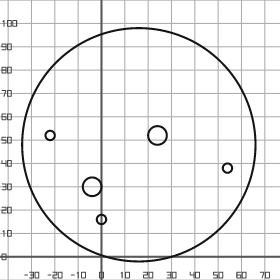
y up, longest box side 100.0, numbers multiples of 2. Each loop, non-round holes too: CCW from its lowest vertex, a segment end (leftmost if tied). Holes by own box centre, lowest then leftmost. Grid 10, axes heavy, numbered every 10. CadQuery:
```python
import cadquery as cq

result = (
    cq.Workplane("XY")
    .moveTo(16.0, 48.0)
    .circle(50.0)
    .moveTo(0.0, 16.0)
    .circle(2.0)
    .moveTo(-4.0, 30.0)
    .circle(4.0)
    .moveTo(54.0, 38.0)
    .circle(2.0)
    .moveTo(-22.0, 52.0)
    .circle(2.0)
    .moveTo(24.0, 52.0)
    .circle(4.0)
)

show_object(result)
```